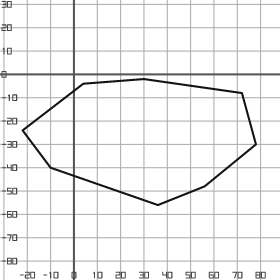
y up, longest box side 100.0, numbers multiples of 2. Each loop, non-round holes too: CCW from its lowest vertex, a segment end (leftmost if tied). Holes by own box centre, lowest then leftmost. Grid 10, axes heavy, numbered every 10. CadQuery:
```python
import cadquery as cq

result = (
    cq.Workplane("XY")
    .moveTo(36.0, -56.0)
    .lineTo(56.0, -48.0)
    .lineTo(78.0, -30.0)
    .lineTo(72.0, -8.0)
    .lineTo(30.0, -2.0)
    .lineTo(4.0, -4.0)
    .lineTo(-22.0, -24.0)
    .lineTo(-10.0, -40.0)
    .close()
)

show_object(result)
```